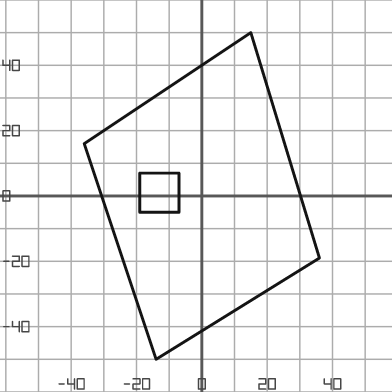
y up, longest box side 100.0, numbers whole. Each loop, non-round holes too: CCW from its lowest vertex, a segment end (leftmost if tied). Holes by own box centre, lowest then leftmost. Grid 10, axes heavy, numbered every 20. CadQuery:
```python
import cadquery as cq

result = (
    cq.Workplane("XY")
    .moveTo(-14.0, -50.0)
    .lineTo(36.0, -19.0)
    .lineTo(15.0, 50.0)
    .lineTo(-36.0, 16.0)
    .close()
    .moveTo(-19.0, -5.0)
    .lineTo(-7.0, -5.0)
    .lineTo(-7.0, 7.0)
    .lineTo(-19.0, 7.0)
    .close()
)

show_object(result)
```